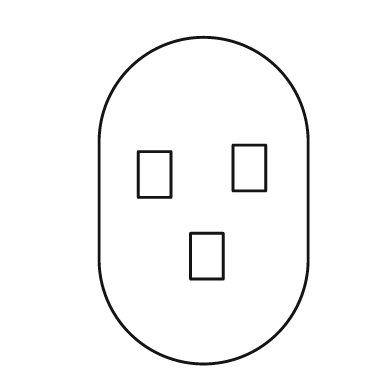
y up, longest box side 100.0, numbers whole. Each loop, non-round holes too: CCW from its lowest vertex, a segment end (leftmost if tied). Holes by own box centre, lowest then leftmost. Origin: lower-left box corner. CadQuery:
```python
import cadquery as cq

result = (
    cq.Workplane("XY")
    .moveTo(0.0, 32.0)
    .threePointArc((32.0, 0.0), (64.0, 32.0))
    .lineTo(64.0, 68.0)
    .threePointArc((32.0, 100.0), (0.0, 68.0))
    .close()
    .moveTo(28.0, 26.0)
    .lineTo(38.0, 26.0)
    .lineTo(38.0, 40.0)
    .lineTo(28.0, 40.0)
    .close()
    .moveTo(12.0, 51.0)
    .lineTo(22.0, 51.0)
    .lineTo(22.0, 65.0)
    .lineTo(12.0, 65.0)
    .close()
    .moveTo(41.0, 53.0)
    .lineTo(51.0, 53.0)
    .lineTo(51.0, 67.0)
    .lineTo(41.0, 67.0)
    .close()
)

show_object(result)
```